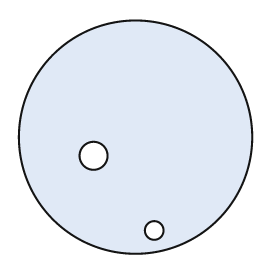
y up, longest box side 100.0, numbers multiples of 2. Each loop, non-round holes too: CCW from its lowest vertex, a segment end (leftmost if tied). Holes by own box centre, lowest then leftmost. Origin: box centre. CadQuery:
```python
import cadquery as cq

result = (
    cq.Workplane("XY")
    .moveTo(0.0, 0.0)
    .circle(50.0)
    .moveTo(8.0, -40.0)
    .circle(4.0)
    .moveTo(-18.0, -8.0)
    .circle(6.0)
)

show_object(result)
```